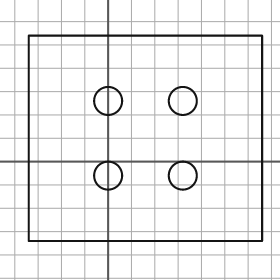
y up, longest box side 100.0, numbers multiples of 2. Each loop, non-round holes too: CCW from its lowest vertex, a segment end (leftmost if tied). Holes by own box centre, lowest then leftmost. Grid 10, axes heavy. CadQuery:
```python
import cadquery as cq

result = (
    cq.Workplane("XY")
    .moveTo(-34.0, -34.0)
    .lineTo(66.0, -34.0)
    .lineTo(66.0, 54.0)
    .lineTo(-34.0, 54.0)
    .close()
    .moveTo(0.0, -6.0)
    .circle(6.0)
    .moveTo(32.0, -6.0)
    .circle(6.0)
    .moveTo(0.0, 26.0)
    .circle(6.0)
    .moveTo(32.0, 26.0)
    .circle(6.0)
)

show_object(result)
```